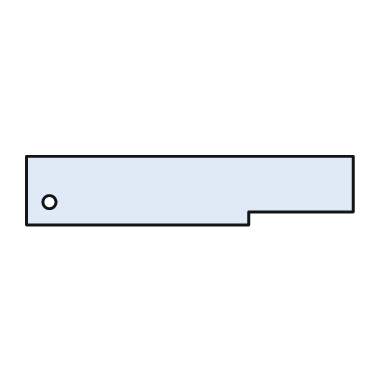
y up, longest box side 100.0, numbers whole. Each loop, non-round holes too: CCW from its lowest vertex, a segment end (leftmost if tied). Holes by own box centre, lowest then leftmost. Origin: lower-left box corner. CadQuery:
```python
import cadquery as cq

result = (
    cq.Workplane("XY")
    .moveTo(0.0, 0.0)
    .lineTo(68.0, 0.0)
    .lineTo(68.0, 4.0)
    .lineTo(100.0, 4.0)
    .lineTo(100.0, 21.0)
    .lineTo(0.0, 21.0)
    .close()
    .moveTo(7.0, 7.0)
    .circle(2.0)
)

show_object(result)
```